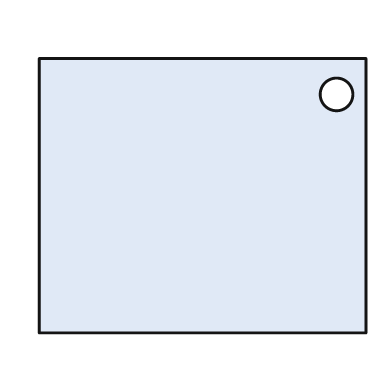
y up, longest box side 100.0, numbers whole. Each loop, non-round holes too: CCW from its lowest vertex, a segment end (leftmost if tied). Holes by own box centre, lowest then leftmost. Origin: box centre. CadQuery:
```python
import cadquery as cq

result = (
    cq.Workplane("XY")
    .moveTo(-50.0, -42.0)
    .lineTo(50.0, -42.0)
    .lineTo(50.0, 42.0)
    .lineTo(-50.0, 42.0)
    .close()
    .moveTo(41.0, 31.0)
    .circle(5.0)
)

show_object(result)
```